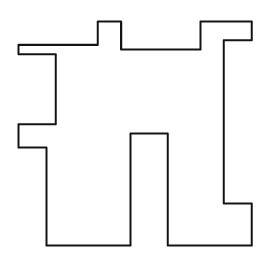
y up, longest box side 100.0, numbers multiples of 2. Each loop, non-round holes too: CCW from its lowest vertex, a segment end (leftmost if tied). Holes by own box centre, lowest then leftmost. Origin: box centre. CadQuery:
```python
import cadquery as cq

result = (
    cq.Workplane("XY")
    .moveTo(-38.0, -48.0)
    .lineTo(-2.0, -48.0)
    .lineTo(-2.0, 0.0)
    .lineTo(14.0, 0.0)
    .lineTo(14.0, -48.0)
    .lineTo(50.0, -48.0)
    .lineTo(50.0, -30.0)
    .lineTo(38.0, -30.0)
    .lineTo(38.0, 40.0)
    .lineTo(50.0, 40.0)
    .lineTo(50.0, 48.0)
    .lineTo(28.0, 48.0)
    .lineTo(28.0, 36.0)
    .lineTo(-6.0, 36.0)
    .lineTo(-6.0, 48.0)
    .lineTo(-16.0, 48.0)
    .lineTo(-16.0, 38.0)
    .lineTo(-50.0, 38.0)
    .lineTo(-50.0, 34.0)
    .lineTo(-34.0, 34.0)
    .lineTo(-34.0, 4.0)
    .lineTo(-50.0, 4.0)
    .lineTo(-50.0, -6.0)
    .lineTo(-38.0, -6.0)
    .close()
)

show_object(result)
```